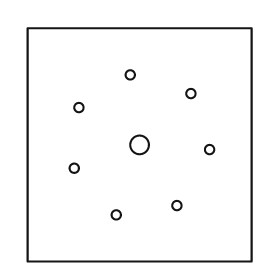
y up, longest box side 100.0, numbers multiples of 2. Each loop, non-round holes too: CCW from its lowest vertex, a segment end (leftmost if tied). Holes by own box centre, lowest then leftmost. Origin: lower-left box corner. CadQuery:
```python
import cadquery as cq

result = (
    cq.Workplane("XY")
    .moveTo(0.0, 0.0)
    .lineTo(96.0, 0.0)
    .lineTo(96.0, 100.0)
    .lineTo(0.0, 100.0)
    .close()
    .moveTo(38.0, 20.0)
    .circle(2.0)
    .moveTo(64.0, 24.0)
    .circle(2.0)
    .moveTo(20.0, 40.0)
    .circle(2.0)
    .moveTo(78.0, 48.0)
    .circle(2.0)
    .moveTo(48.0, 50.0)
    .circle(4.0)
    .moveTo(22.0, 66.0)
    .circle(2.0)
    .moveTo(70.0, 72.0)
    .circle(2.0)
    .moveTo(44.0, 80.0)
    .circle(2.0)
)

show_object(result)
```